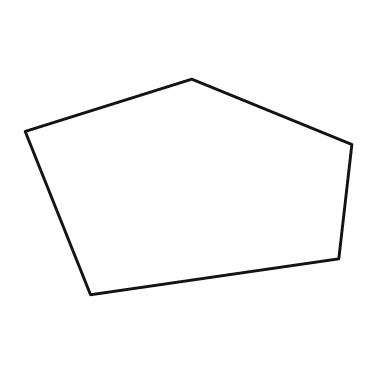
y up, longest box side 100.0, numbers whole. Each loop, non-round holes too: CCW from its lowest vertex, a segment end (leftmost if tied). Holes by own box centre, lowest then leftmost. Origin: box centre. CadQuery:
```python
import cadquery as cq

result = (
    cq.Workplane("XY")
    .moveTo(-30.0, -33.0)
    .lineTo(46.0, -22.0)
    .lineTo(50.0, 13.0)
    .lineTo(1.0, 33.0)
    .lineTo(-50.0, 17.0)
    .close()
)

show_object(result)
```